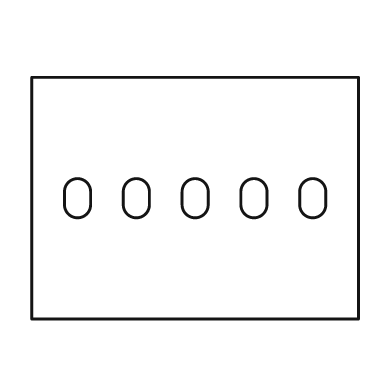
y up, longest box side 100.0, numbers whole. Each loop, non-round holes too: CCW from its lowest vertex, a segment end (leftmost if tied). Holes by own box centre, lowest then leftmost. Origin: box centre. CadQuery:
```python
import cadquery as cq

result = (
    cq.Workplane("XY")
    .moveTo(-50.0, -37.0)
    .lineTo(50.0, -37.0)
    .lineTo(50.0, 37.0)
    .lineTo(-50.0, 37.0)
    .close()
    .moveTo(-40.0, -2.0)
    .threePointArc((-36.0, -6.0), (-32.0, -2.0))
    .lineTo(-32.0, 2.0)
    .threePointArc((-36.0, 6.0), (-40.0, 2.0))
    .close()
    .moveTo(-22.0, -2.0)
    .threePointArc((-18.0, -6.0), (-14.0, -2.0))
    .lineTo(-14.0, 2.0)
    .threePointArc((-18.0, 6.0), (-22.0, 2.0))
    .close()
    .moveTo(-4.0, -2.0)
    .threePointArc((0.0, -6.0), (4.0, -2.0))
    .lineTo(4.0, 2.0)
    .threePointArc((0.0, 6.0), (-4.0, 2.0))
    .close()
    .moveTo(14.0, -2.0)
    .threePointArc((18.0, -6.0), (22.0, -2.0))
    .lineTo(22.0, 2.0)
    .threePointArc((18.0, 6.0), (14.0, 2.0))
    .close()
    .moveTo(32.0, -2.0)
    .threePointArc((36.0, -6.0), (40.0, -2.0))
    .lineTo(40.0, 2.0)
    .threePointArc((36.0, 6.0), (32.0, 2.0))
    .close()
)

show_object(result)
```